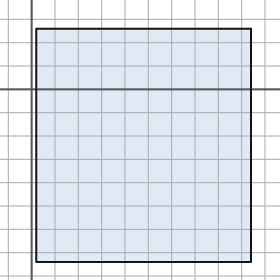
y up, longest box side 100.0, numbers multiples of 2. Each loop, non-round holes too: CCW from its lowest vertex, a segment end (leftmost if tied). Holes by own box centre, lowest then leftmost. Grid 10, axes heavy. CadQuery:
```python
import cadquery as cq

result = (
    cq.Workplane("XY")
    .moveTo(2.0, -74.0)
    .lineTo(94.0, -74.0)
    .lineTo(94.0, 26.0)
    .lineTo(2.0, 26.0)
    .close()
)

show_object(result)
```